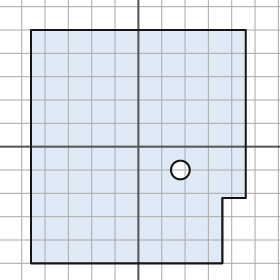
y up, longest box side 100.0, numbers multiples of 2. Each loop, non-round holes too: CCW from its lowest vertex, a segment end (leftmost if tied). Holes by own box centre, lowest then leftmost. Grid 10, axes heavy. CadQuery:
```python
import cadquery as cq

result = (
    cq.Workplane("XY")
    .moveTo(-46.0, -50.0)
    .lineTo(36.0, -50.0)
    .lineTo(36.0, -22.0)
    .lineTo(46.0, -22.0)
    .lineTo(46.0, 50.0)
    .lineTo(-46.0, 50.0)
    .close()
    .moveTo(18.0, -10.0)
    .circle(4.0)
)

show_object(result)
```